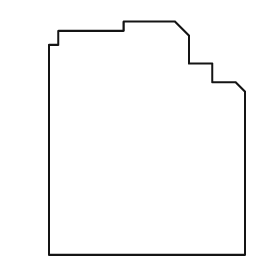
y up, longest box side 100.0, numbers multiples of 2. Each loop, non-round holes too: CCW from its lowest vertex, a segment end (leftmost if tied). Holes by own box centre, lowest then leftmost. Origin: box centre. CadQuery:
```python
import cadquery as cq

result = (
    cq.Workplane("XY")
    .moveTo(-42.0, -50.0)
    .lineTo(42.0, -50.0)
    .lineTo(42.0, 20.0)
    .lineTo(38.0, 24.0)
    .lineTo(28.0, 24.0)
    .lineTo(28.0, 32.0)
    .lineTo(18.0, 32.0)
    .lineTo(18.0, 44.0)
    .lineTo(12.0, 50.0)
    .lineTo(-10.0, 50.0)
    .lineTo(-10.0, 46.0)
    .lineTo(-38.0, 46.0)
    .lineTo(-38.0, 40.0)
    .lineTo(-42.0, 40.0)
    .close()
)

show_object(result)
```